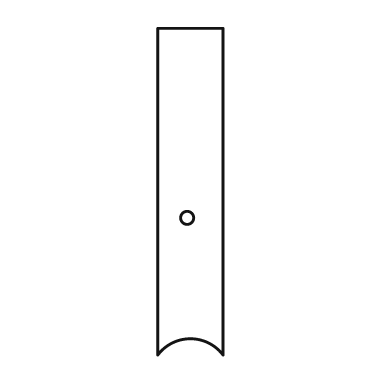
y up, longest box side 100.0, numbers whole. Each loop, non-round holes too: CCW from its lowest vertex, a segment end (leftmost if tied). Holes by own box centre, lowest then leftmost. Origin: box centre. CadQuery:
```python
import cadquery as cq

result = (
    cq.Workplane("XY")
    .moveTo(-10.0, -50.0)
    .threePointArc((0.0, -45.0), (10.0, -50.0))
    .lineTo(10.0, 50.0)
    .lineTo(-10.0, 50.0)
    .close()
    .moveTo(-1.0, -8.0)
    .circle(2.0)
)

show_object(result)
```